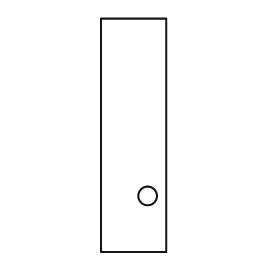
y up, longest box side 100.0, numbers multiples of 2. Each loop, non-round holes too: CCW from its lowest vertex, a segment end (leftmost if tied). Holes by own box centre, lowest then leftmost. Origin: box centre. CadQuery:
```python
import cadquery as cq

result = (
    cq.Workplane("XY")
    .moveTo(-14.0, -50.0)
    .lineTo(14.0, -50.0)
    .lineTo(14.0, 50.0)
    .lineTo(-14.0, 50.0)
    .close()
    .moveTo(6.0, -26.0)
    .circle(4.0)
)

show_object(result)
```